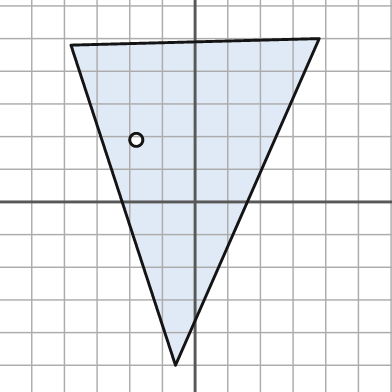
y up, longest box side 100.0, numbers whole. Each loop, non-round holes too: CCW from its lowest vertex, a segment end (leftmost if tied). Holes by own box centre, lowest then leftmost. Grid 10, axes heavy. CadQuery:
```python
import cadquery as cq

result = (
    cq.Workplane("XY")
    .moveTo(-6.0, -50.0)
    .lineTo(38.0, 50.0)
    .lineTo(-38.0, 48.0)
    .close()
    .moveTo(-18.0, 19.0)
    .circle(2.0)
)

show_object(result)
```